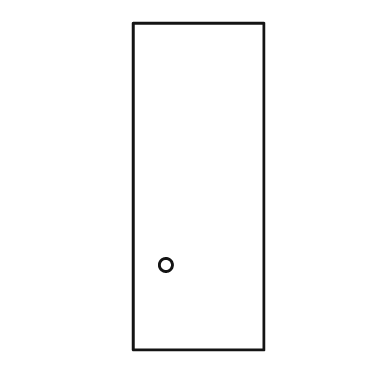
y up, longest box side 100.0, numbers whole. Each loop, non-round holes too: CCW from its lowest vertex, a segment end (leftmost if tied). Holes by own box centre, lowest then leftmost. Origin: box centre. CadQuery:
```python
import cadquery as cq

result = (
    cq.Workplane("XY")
    .moveTo(-20.0, -50.0)
    .lineTo(20.0, -50.0)
    .lineTo(20.0, 50.0)
    .lineTo(-20.0, 50.0)
    .close()
    .moveTo(-10.0, -24.0)
    .circle(2.0)
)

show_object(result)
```